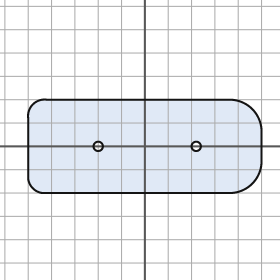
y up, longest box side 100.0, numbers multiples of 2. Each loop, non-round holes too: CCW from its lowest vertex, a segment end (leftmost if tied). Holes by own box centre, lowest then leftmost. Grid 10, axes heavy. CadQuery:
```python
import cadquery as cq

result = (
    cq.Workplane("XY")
    .moveTo(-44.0, -20.0)
    .lineTo(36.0, -20.0)
    .threePointArc((46.0, -16.0), (50.0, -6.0))
    .lineTo(50.0, 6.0)
    .threePointArc((46.0, 16.0), (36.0, 20.0))
    .lineTo(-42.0, 20.0)
    .threePointArc((-48.0, 18.0), (-50.0, 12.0))
    .lineTo(-50.0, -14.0)
    .threePointArc((-48.0, -18.0), (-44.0, -20.0))
    .close()
    .moveTo(-20.0, 0.0)
    .circle(2.0)
    .moveTo(22.0, 0.0)
    .circle(2.0)
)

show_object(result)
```